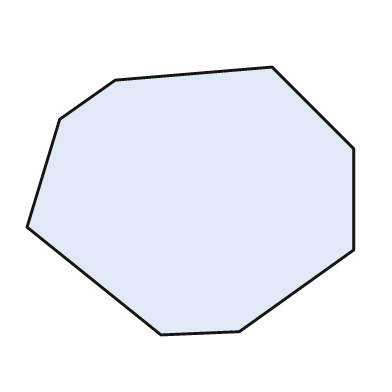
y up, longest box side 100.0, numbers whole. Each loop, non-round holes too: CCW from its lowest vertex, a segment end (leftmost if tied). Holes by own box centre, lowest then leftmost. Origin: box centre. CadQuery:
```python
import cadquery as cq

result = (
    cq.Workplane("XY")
    .moveTo(-9.0, -41.0)
    .lineTo(15.0, -40.0)
    .lineTo(50.0, -15.0)
    .lineTo(50.0, 16.0)
    .lineTo(25.0, 41.0)
    .lineTo(-23.0, 37.0)
    .lineTo(-40.0, 25.0)
    .lineTo(-50.0, -8.0)
    .close()
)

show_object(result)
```